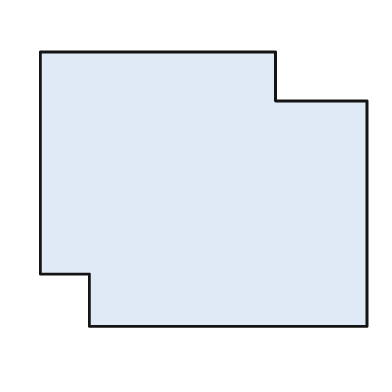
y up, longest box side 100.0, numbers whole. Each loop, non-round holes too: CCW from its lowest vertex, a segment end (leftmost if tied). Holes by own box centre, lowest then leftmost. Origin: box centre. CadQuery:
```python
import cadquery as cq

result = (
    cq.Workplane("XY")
    .moveTo(-35.0, -42.0)
    .lineTo(50.0, -42.0)
    .lineTo(50.0, 27.0)
    .lineTo(22.0, 27.0)
    .lineTo(22.0, 42.0)
    .lineTo(-50.0, 42.0)
    .lineTo(-50.0, -26.0)
    .lineTo(-35.0, -26.0)
    .close()
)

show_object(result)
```